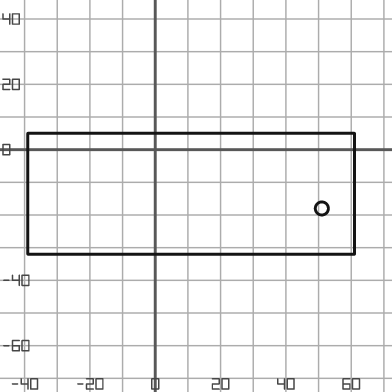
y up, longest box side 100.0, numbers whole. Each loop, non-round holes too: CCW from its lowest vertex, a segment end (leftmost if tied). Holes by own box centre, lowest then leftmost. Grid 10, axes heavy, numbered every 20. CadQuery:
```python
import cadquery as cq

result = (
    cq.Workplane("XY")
    .moveTo(-39.0, -32.0)
    .lineTo(61.0, -32.0)
    .lineTo(61.0, 5.0)
    .lineTo(-39.0, 5.0)
    .close()
    .moveTo(51.0, -18.0)
    .circle(2.0)
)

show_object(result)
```